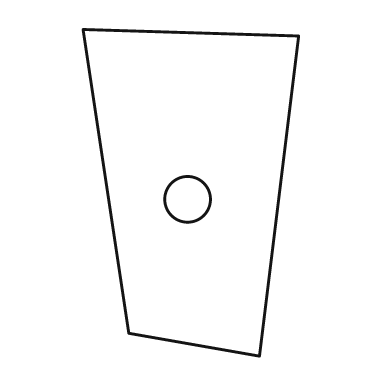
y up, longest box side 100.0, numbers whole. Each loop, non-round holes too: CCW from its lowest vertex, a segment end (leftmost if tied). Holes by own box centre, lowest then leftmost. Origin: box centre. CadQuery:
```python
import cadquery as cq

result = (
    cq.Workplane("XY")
    .moveTo(21.0, -50.0)
    .lineTo(33.0, 48.0)
    .lineTo(-33.0, 50.0)
    .lineTo(-19.0, -43.0)
    .close()
    .moveTo(-1.0, -2.0)
    .circle(7.0)
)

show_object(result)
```